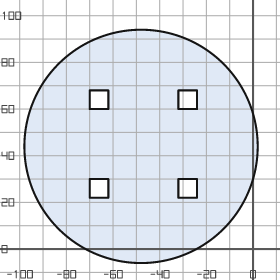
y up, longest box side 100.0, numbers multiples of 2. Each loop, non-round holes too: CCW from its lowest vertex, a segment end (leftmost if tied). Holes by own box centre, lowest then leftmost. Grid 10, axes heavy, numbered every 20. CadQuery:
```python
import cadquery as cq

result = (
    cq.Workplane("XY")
    .moveTo(-48.0, 44.0)
    .circle(50.0)
    .moveTo(-70.0, 22.0)
    .lineTo(-62.0, 22.0)
    .lineTo(-62.0, 30.0)
    .lineTo(-70.0, 30.0)
    .close()
    .moveTo(-32.0, 22.0)
    .lineTo(-24.0, 22.0)
    .lineTo(-24.0, 30.0)
    .lineTo(-32.0, 30.0)
    .close()
    .moveTo(-70.0, 60.0)
    .lineTo(-62.0, 60.0)
    .lineTo(-62.0, 68.0)
    .lineTo(-70.0, 68.0)
    .close()
    .moveTo(-32.0, 60.0)
    .lineTo(-24.0, 60.0)
    .lineTo(-24.0, 68.0)
    .lineTo(-32.0, 68.0)
    .close()
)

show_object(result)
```